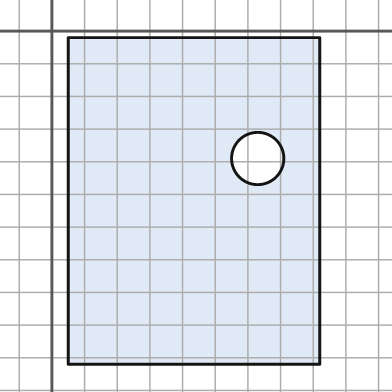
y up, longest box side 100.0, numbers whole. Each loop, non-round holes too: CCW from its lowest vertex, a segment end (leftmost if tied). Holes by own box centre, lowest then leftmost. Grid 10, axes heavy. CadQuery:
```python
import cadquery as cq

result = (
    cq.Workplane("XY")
    .moveTo(5.0, -102.0)
    .lineTo(82.0, -102.0)
    .lineTo(82.0, -2.0)
    .lineTo(5.0, -2.0)
    .close()
    .moveTo(63.0, -39.0)
    .circle(8.0)
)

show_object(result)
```